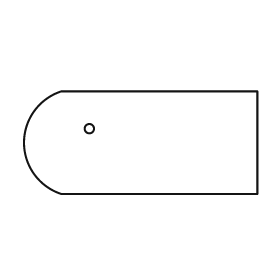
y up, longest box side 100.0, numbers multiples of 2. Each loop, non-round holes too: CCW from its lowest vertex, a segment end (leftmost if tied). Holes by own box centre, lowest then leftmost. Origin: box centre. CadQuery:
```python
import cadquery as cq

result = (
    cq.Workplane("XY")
    .moveTo(-34.0, -22.0)
    .lineTo(50.0, -22.0)
    .lineTo(50.0, 22.0)
    .lineTo(-34.0, 22.0)
    .threePointArc((-50.0, 0.0), (-34.0, -22.0))
    .close()
    .moveTo(-22.0, 6.0)
    .circle(2.0)
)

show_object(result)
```